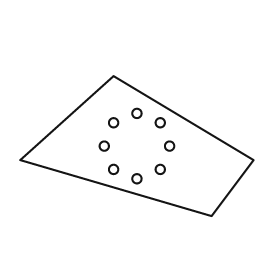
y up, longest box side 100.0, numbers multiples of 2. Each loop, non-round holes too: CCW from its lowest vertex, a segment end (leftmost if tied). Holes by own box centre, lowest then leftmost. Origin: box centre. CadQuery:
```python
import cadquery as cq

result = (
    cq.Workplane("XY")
    .moveTo(32.0, -30.0)
    .lineTo(50.0, -6.0)
    .lineTo(-10.0, 30.0)
    .lineTo(-50.0, -6.0)
    .close()
    .moveTo(0.0, -14.0)
    .circle(2.0)
    .moveTo(-10.0, -10.0)
    .circle(2.0)
    .moveTo(10.0, -10.0)
    .circle(2.0)
    .moveTo(-14.0, 0.0)
    .circle(2.0)
    .moveTo(14.0, 0.0)
    .circle(2.0)
    .moveTo(-10.0, 10.0)
    .circle(2.0)
    .moveTo(10.0, 10.0)
    .circle(2.0)
    .moveTo(0.0, 14.0)
    .circle(2.0)
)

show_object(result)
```